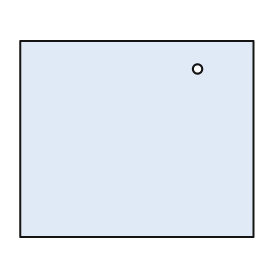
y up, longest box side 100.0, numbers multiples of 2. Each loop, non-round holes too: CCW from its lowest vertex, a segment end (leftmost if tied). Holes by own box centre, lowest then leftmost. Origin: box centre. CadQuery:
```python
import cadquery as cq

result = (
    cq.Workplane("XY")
    .moveTo(-50.0, -42.0)
    .lineTo(50.0, -42.0)
    .lineTo(50.0, 42.0)
    .lineTo(-50.0, 42.0)
    .close()
    .moveTo(26.0, 30.0)
    .circle(2.0)
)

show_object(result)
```